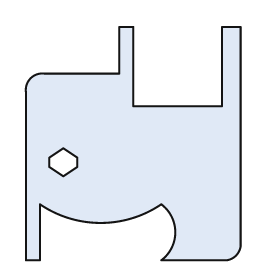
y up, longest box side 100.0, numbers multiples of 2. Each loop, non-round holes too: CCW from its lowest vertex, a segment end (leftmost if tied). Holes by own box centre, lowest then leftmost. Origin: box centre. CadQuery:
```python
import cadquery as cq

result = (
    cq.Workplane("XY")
    .moveTo(-46.0, -50.0)
    .lineTo(-40.0, -50.0)
    .lineTo(-40.0, -26.0)
    .threePointArc((-14.0, -34.0), (12.0, -26.0))
    .threePointArc((18.0, -38.0), (12.0, -50.0))
    .lineTo(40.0, -50.0)
    .threePointArc((44.0, -48.0), (46.0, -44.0))
    .lineTo(46.0, 50.0)
    .lineTo(38.0, 50.0)
    .lineTo(38.0, 16.0)
    .lineTo(0.0, 16.0)
    .lineTo(0.0, 50.0)
    .lineTo(-6.0, 50.0)
    .lineTo(-6.0, 30.0)
    .lineTo(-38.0, 30.0)
    .threePointArc((-44.0, 28.0), (-46.0, 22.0))
    .close()
    .moveTo(-30.0, -14.0)
    .lineTo(-24.0, -10.0)
    .lineTo(-24.0, -6.0)
    .lineTo(-30.0, -2.0)
    .lineTo(-36.0, -6.0)
    .lineTo(-36.0, -10.0)
    .close()
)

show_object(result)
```